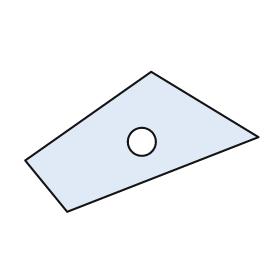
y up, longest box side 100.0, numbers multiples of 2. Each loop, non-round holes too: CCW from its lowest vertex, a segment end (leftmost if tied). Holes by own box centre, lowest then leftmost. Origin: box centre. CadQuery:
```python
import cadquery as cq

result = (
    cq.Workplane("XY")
    .moveTo(-32.0, -30.0)
    .lineTo(50.0, 2.0)
    .lineTo(4.0, 30.0)
    .lineTo(-50.0, -8.0)
    .close()
    .moveTo(0.0, 0.0)
    .circle(6.0)
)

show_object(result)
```